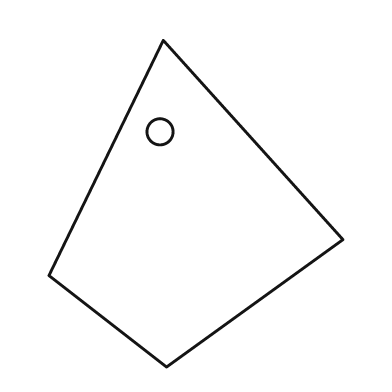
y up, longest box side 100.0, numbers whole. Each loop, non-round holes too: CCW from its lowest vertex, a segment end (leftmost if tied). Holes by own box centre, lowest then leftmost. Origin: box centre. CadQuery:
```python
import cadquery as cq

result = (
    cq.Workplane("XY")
    .moveTo(-9.0, -50.0)
    .lineTo(45.0, -11.0)
    .lineTo(-10.0, 50.0)
    .lineTo(-45.0, -22.0)
    .close()
    .moveTo(-11.0, 22.0)
    .circle(4.0)
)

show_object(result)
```